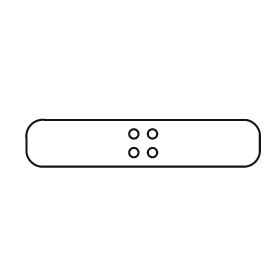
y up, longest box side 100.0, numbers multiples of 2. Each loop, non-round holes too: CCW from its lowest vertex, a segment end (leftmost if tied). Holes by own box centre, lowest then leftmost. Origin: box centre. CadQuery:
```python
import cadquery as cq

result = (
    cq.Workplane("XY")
    .moveTo(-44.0, -10.0)
    .lineTo(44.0, -10.0)
    .threePointArc((48.0, -8.0), (50.0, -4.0))
    .lineTo(50.0, 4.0)
    .threePointArc((48.0, 8.0), (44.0, 10.0))
    .lineTo(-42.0, 10.0)
    .threePointArc((-48.0, 8.0), (-50.0, 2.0))
    .lineTo(-50.0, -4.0)
    .threePointArc((-48.0, -8.0), (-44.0, -10.0))
    .close()
    .moveTo(-4.0, -4.0)
    .circle(2.0)
    .moveTo(4.0, -4.0)
    .circle(2.0)
    .moveTo(-4.0, 4.0)
    .circle(2.0)
    .moveTo(4.0, 4.0)
    .circle(2.0)
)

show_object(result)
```